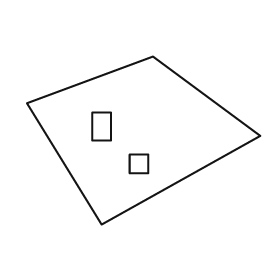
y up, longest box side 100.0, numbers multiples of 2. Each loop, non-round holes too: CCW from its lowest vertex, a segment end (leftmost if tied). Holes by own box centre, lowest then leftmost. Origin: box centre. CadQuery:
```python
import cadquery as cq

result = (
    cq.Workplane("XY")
    .moveTo(-18.0, -36.0)
    .lineTo(50.0, 2.0)
    .lineTo(4.0, 36.0)
    .lineTo(-50.0, 16.0)
    .close()
    .moveTo(-6.0, -14.0)
    .lineTo(2.0, -14.0)
    .lineTo(2.0, -6.0)
    .lineTo(-6.0, -6.0)
    .close()
    .moveTo(-22.0, 0.0)
    .lineTo(-14.0, 0.0)
    .lineTo(-14.0, 12.0)
    .lineTo(-22.0, 12.0)
    .close()
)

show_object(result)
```